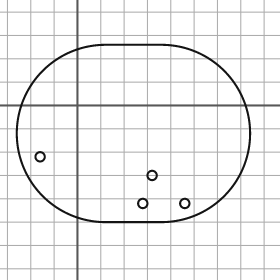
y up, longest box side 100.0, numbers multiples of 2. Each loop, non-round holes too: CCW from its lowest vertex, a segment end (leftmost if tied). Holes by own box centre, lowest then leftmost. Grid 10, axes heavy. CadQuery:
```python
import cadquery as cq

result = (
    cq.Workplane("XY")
    .moveTo(12.0, -50.0)
    .lineTo(36.0, -50.0)
    .threePointArc((74.0, -12.0), (36.0, 26.0))
    .lineTo(12.0, 26.0)
    .threePointArc((-26.0, -12.0), (12.0, -50.0))
    .close()
    .moveTo(28.0, -42.0)
    .circle(2.0)
    .moveTo(46.0, -42.0)
    .circle(2.0)
    .moveTo(32.0, -30.0)
    .circle(2.0)
    .moveTo(-16.0, -22.0)
    .circle(2.0)
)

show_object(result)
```